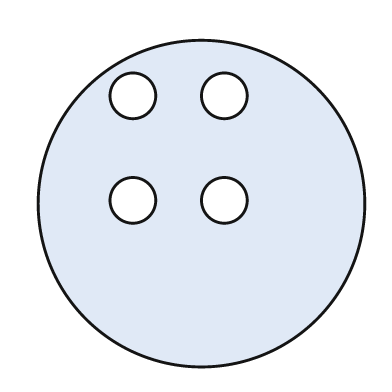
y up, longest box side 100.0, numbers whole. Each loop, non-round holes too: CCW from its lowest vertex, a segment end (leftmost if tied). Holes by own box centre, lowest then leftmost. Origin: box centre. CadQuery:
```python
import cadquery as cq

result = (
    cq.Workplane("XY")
    .moveTo(0.0, 0.0)
    .circle(50.0)
    .moveTo(-21.0, 1.0)
    .circle(7.0)
    .moveTo(7.0, 1.0)
    .circle(7.0)
    .moveTo(-21.0, 33.0)
    .circle(7.0)
    .moveTo(7.0, 33.0)
    .circle(7.0)
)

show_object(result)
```